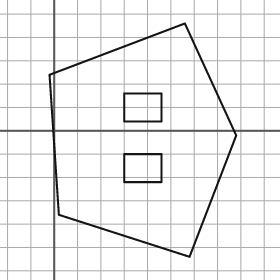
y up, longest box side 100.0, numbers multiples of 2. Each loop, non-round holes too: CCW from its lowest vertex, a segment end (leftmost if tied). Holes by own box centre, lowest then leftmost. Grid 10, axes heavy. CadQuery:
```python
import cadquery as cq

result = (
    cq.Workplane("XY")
    .moveTo(58.0, -54.0)
    .lineTo(78.0, -2.0)
    .lineTo(56.0, 46.0)
    .lineTo(-2.0, 24.0)
    .lineTo(2.0, -36.0)
    .close()
    .moveTo(30.0, -22.0)
    .lineTo(46.0, -22.0)
    .lineTo(46.0, -10.0)
    .lineTo(30.0, -10.0)
    .close()
    .moveTo(30.0, 4.0)
    .lineTo(46.0, 4.0)
    .lineTo(46.0, 16.0)
    .lineTo(30.0, 16.0)
    .close()
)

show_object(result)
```